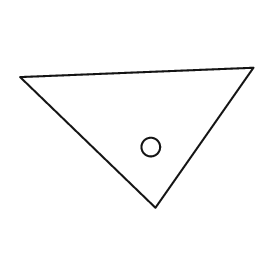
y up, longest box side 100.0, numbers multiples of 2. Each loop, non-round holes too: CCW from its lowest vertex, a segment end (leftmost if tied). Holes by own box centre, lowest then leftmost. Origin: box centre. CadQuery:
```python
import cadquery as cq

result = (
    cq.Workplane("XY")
    .moveTo(8.0, -30.0)
    .lineTo(50.0, 30.0)
    .lineTo(-50.0, 26.0)
    .close()
    .moveTo(6.0, -4.0)
    .circle(4.0)
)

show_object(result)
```